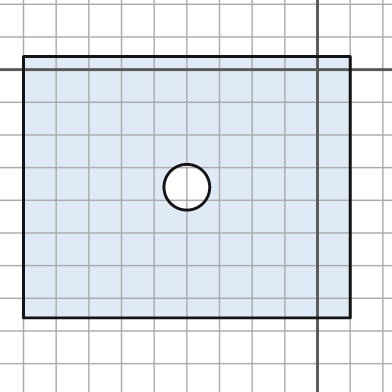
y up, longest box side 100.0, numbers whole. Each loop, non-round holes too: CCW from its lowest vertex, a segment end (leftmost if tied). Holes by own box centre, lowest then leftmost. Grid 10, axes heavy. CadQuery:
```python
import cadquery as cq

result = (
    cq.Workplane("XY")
    .moveTo(-90.0, -76.0)
    .lineTo(10.0, -76.0)
    .lineTo(10.0, 4.0)
    .lineTo(-90.0, 4.0)
    .close()
    .moveTo(-40.0, -36.0)
    .circle(7.0)
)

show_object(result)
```